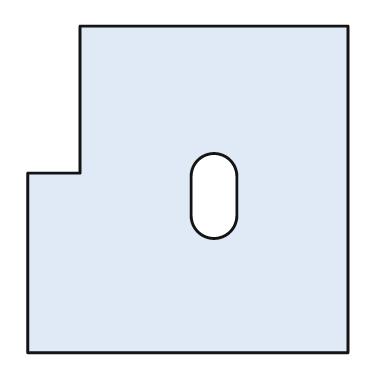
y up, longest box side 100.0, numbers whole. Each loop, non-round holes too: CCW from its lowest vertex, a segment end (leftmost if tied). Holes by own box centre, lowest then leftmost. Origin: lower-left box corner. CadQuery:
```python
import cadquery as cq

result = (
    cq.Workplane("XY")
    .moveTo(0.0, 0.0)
    .lineTo(98.0, 0.0)
    .lineTo(98.0, 100.0)
    .lineTo(16.0, 100.0)
    .lineTo(16.0, 55.0)
    .lineTo(0.0, 55.0)
    .close()
    .moveTo(50.0, 42.0)
    .threePointArc((57.0, 35.0), (64.0, 42.0))
    .lineTo(64.0, 54.0)
    .threePointArc((57.0, 61.0), (50.0, 54.0))
    .close()
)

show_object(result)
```